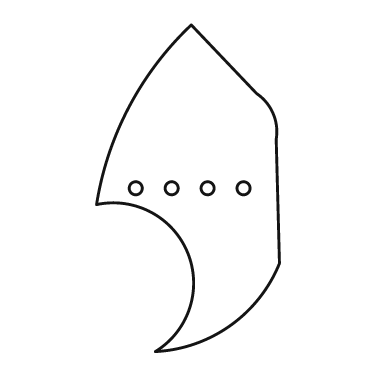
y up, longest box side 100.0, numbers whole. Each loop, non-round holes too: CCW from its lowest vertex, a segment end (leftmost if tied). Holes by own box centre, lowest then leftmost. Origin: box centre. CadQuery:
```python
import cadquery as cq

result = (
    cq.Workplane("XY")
    .moveTo(-10.0, -50.0)
    .threePointArc((13.0, -42.0), (28.0, -23.0))
    .lineTo(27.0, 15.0)
    .threePointArc((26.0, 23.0), (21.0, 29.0))
    .lineTo(1.0, 50.0)
    .threePointArc((-18.0, 25.0), (-28.0, -5.0))
    .threePointArc((0.0, -20.0), (-10.0, -50.0))
    .close()
    .moveTo(-16.0, 0.0)
    .circle(2.0)
    .moveTo(-5.0, 0.0)
    .circle(2.0)
    .moveTo(6.0, 0.0)
    .circle(2.0)
    .moveTo(17.0, 0.0)
    .circle(2.0)
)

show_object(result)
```